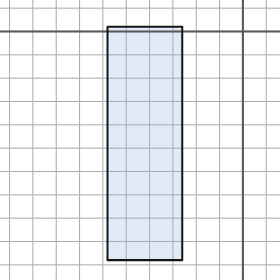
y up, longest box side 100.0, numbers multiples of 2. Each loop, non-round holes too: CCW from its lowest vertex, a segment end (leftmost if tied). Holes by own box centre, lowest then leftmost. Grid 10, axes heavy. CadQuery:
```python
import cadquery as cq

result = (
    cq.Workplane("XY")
    .moveTo(-58.0, -98.0)
    .lineTo(-26.0, -98.0)
    .lineTo(-26.0, 2.0)
    .lineTo(-58.0, 2.0)
    .close()
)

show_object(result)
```